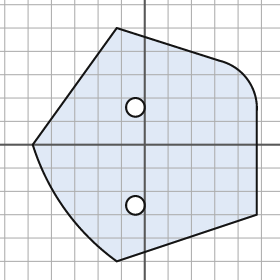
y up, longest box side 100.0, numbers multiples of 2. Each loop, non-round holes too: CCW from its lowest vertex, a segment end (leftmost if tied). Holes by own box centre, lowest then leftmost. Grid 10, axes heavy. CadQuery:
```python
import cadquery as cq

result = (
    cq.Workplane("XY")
    .moveTo(-12.0, -50.0)
    .lineTo(48.0, -30.0)
    .lineTo(48.0, 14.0)
    .threePointArc((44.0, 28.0), (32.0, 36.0))
    .lineTo(-12.0, 50.0)
    .lineTo(-48.0, 0.0)
    .threePointArc((-34.0, -28.0), (-12.0, -50.0))
    .close()
    .moveTo(-4.0, -26.0)
    .circle(4.0)
    .moveTo(-4.0, 16.0)
    .circle(4.0)
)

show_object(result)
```